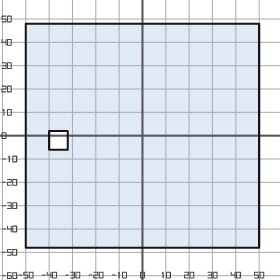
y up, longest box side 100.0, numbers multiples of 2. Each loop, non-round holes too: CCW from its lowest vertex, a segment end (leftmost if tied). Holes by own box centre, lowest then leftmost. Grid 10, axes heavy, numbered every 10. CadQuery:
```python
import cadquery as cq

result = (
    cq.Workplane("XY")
    .moveTo(-50.0, -48.0)
    .lineTo(50.0, -48.0)
    .lineTo(50.0, 48.0)
    .lineTo(-50.0, 48.0)
    .close()
    .moveTo(-40.0, -6.0)
    .lineTo(-32.0, -6.0)
    .lineTo(-32.0, 2.0)
    .lineTo(-40.0, 2.0)
    .close()
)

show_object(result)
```